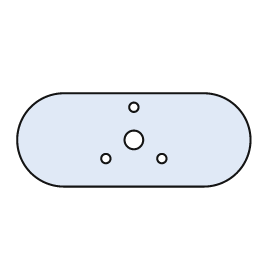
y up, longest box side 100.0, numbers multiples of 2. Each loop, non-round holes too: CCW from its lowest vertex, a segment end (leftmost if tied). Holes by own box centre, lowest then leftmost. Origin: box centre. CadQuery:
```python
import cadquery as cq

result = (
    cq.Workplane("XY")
    .moveTo(-30.0, -20.0)
    .lineTo(30.0, -20.0)
    .threePointArc((50.0, 0.0), (30.0, 20.0))
    .lineTo(-30.0, 20.0)
    .threePointArc((-50.0, 0.0), (-30.0, -20.0))
    .close()
    .moveTo(-12.0, -8.0)
    .circle(2.0)
    .moveTo(12.0, -8.0)
    .circle(2.0)
    .moveTo(0.0, 0.0)
    .circle(4.0)
    .moveTo(0.0, 14.0)
    .circle(2.0)
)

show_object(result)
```